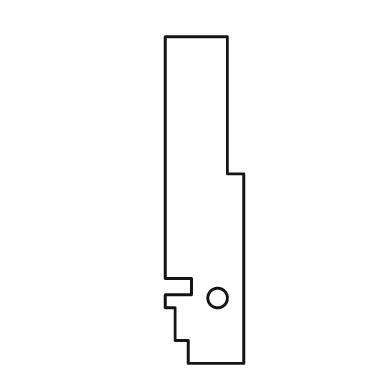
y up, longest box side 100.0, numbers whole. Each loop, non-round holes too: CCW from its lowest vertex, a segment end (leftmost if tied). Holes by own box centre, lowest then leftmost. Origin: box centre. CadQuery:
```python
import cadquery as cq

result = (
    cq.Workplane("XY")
    .moveTo(-5.0, -50.0)
    .lineTo(12.0, -50.0)
    .lineTo(12.0, 8.0)
    .lineTo(7.0, 8.0)
    .lineTo(7.0, 50.0)
    .lineTo(-12.0, 50.0)
    .lineTo(-12.0, -24.0)
    .lineTo(-4.0, -24.0)
    .lineTo(-4.0, -29.0)
    .lineTo(-12.0, -29.0)
    .lineTo(-12.0, -33.0)
    .lineTo(-9.0, -33.0)
    .lineTo(-9.0, -43.0)
    .lineTo(-5.0, -43.0)
    .close()
    .moveTo(4.0, -30.0)
    .circle(3.0)
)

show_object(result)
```